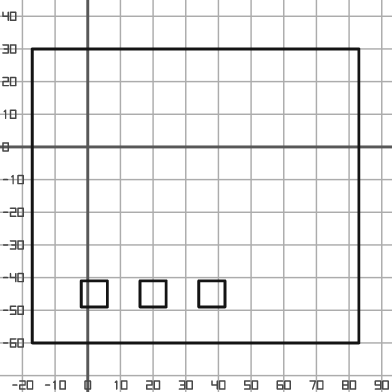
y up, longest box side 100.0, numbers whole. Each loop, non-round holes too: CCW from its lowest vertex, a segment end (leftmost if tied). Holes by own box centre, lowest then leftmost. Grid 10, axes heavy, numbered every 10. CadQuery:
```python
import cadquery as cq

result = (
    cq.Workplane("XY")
    .moveTo(-17.0, -60.0)
    .lineTo(83.0, -60.0)
    .lineTo(83.0, 30.0)
    .lineTo(-17.0, 30.0)
    .close()
    .moveTo(-2.0, -49.0)
    .lineTo(6.0, -49.0)
    .lineTo(6.0, -41.0)
    .lineTo(-2.0, -41.0)
    .close()
    .moveTo(16.0, -49.0)
    .lineTo(24.0, -49.0)
    .lineTo(24.0, -41.0)
    .lineTo(16.0, -41.0)
    .close()
    .moveTo(34.0, -49.0)
    .lineTo(42.0, -49.0)
    .lineTo(42.0, -41.0)
    .lineTo(34.0, -41.0)
    .close()
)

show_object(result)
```